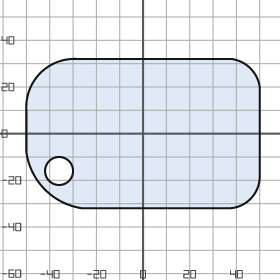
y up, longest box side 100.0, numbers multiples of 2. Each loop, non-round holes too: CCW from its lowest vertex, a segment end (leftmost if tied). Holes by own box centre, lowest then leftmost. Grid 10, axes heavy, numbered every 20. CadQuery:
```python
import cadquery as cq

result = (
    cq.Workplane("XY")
    .moveTo(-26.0, -32.0)
    .lineTo(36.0, -32.0)
    .threePointArc((46.0, -28.0), (50.0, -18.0))
    .lineTo(50.0, 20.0)
    .threePointArc((46.0, 28.0), (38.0, 32.0))
    .lineTo(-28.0, 32.0)
    .threePointArc((-44.0, 26.0), (-50.0, 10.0))
    .lineTo(-50.0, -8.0)
    .threePointArc((-42.0, -24.0), (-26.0, -32.0))
    .close()
    .moveTo(-36.0, -16.0)
    .circle(6.0)
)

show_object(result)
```